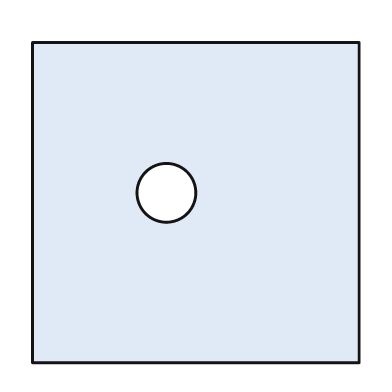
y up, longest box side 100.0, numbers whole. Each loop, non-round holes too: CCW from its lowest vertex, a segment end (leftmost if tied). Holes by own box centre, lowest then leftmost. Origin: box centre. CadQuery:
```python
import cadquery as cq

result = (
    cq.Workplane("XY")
    .moveTo(-50.0, -49.0)
    .lineTo(50.0, -49.0)
    .lineTo(50.0, 49.0)
    .lineTo(-50.0, 49.0)
    .close()
    .moveTo(-9.0, 3.0)
    .circle(9.0)
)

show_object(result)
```